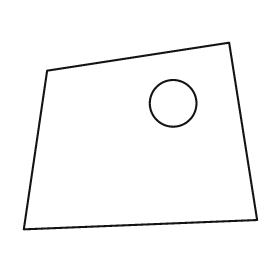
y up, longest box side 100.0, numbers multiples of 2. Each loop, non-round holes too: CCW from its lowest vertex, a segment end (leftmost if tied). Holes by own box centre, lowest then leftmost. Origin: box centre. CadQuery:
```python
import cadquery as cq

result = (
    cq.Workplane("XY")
    .moveTo(-50.0, -40.0)
    .lineTo(50.0, -36.0)
    .lineTo(38.0, 40.0)
    .lineTo(-40.0, 28.0)
    .close()
    .moveTo(14.0, 14.0)
    .circle(10.0)
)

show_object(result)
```